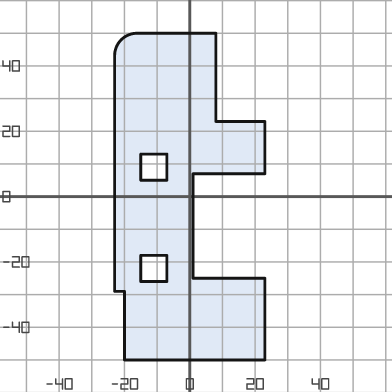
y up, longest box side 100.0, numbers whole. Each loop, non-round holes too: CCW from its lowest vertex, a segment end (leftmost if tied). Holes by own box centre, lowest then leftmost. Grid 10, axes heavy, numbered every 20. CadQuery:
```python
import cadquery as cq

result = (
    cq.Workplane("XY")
    .moveTo(-20.0, -50.0)
    .lineTo(23.0, -50.0)
    .lineTo(23.0, -25.0)
    .lineTo(1.0, -25.0)
    .lineTo(1.0, 7.0)
    .lineTo(23.0, 7.0)
    .lineTo(23.0, 23.0)
    .lineTo(8.0, 23.0)
    .lineTo(8.0, 50.0)
    .lineTo(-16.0, 50.0)
    .threePointArc((-21.0, 48.0), (-23.0, 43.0))
    .lineTo(-23.0, -29.0)
    .lineTo(-20.0, -29.0)
    .close()
    .moveTo(-15.0, -26.0)
    .lineTo(-7.0, -26.0)
    .lineTo(-7.0, -18.0)
    .lineTo(-15.0, -18.0)
    .close()
    .moveTo(-15.0, 5.0)
    .lineTo(-7.0, 5.0)
    .lineTo(-7.0, 13.0)
    .lineTo(-15.0, 13.0)
    .close()
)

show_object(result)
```